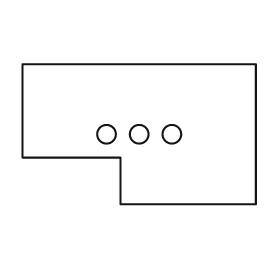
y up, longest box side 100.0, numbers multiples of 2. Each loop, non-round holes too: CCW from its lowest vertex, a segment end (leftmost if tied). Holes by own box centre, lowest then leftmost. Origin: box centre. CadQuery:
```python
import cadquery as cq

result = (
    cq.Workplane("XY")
    .moveTo(-8.0, -30.0)
    .lineTo(50.0, -30.0)
    .lineTo(50.0, 30.0)
    .lineTo(-50.0, 30.0)
    .lineTo(-50.0, -10.0)
    .lineTo(-8.0, -10.0)
    .close()
    .moveTo(-14.0, 0.0)
    .circle(4.0)
    .moveTo(0.0, 0.0)
    .circle(4.0)
    .moveTo(14.0, 0.0)
    .circle(4.0)
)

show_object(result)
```